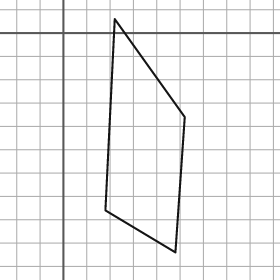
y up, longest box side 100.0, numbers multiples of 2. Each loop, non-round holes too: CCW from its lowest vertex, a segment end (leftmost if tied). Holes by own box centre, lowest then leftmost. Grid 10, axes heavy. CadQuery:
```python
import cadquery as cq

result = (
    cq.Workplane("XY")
    .moveTo(48.0, -94.0)
    .lineTo(52.0, -36.0)
    .lineTo(22.0, 6.0)
    .lineTo(18.0, -76.0)
    .close()
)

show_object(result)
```